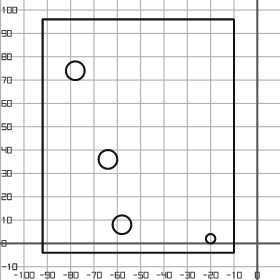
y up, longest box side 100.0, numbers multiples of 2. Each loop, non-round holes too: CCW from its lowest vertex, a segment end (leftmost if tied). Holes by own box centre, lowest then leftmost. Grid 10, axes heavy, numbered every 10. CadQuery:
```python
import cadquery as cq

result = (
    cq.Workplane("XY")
    .moveTo(-92.0, -4.0)
    .lineTo(-10.0, -4.0)
    .lineTo(-10.0, 96.0)
    .lineTo(-92.0, 96.0)
    .close()
    .moveTo(-20.0, 2.0)
    .circle(2.0)
    .moveTo(-58.0, 8.0)
    .circle(4.0)
    .moveTo(-64.0, 36.0)
    .circle(4.0)
    .moveTo(-78.0, 74.0)
    .circle(4.0)
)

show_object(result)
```